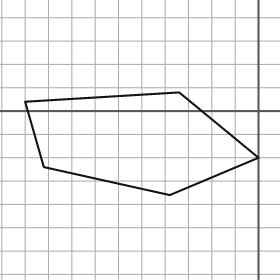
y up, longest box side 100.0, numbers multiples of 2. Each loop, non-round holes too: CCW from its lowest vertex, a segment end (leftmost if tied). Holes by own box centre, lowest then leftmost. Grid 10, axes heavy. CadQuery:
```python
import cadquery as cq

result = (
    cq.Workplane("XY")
    .moveTo(-38.0, -36.0)
    .lineTo(0.0, -20.0)
    .lineTo(-34.0, 8.0)
    .lineTo(-100.0, 4.0)
    .lineTo(-92.0, -24.0)
    .close()
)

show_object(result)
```